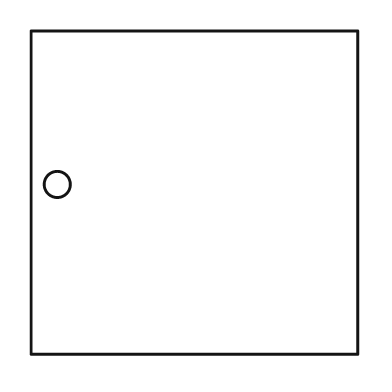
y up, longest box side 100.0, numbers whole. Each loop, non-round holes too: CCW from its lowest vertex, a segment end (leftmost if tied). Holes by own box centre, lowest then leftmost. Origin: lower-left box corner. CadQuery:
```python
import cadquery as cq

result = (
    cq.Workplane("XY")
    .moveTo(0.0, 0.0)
    .lineTo(100.0, 0.0)
    .lineTo(100.0, 99.0)
    .lineTo(0.0, 99.0)
    .close()
    .moveTo(8.0, 52.0)
    .circle(4.0)
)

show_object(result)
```